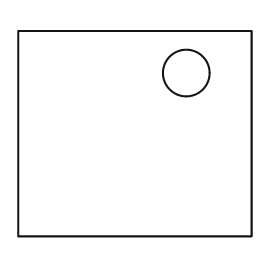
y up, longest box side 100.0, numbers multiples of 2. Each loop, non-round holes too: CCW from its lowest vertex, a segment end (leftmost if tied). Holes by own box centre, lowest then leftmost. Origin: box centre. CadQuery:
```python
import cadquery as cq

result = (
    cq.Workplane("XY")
    .moveTo(-50.0, -44.0)
    .lineTo(50.0, -44.0)
    .lineTo(50.0, 44.0)
    .lineTo(-50.0, 44.0)
    .close()
    .moveTo(22.0, 26.0)
    .circle(10.0)
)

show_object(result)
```